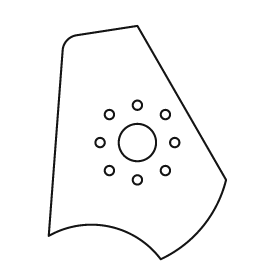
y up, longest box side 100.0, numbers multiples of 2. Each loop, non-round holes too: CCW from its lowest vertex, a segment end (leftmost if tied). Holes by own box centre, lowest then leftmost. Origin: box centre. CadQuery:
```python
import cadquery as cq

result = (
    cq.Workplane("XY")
    .moveTo(10.0, -50.0)
    .threePointArc((28.0, -36.0), (38.0, -16.0))
    .lineTo(0.0, 50.0)
    .lineTo(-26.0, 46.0)
    .threePointArc((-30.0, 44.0), (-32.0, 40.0))
    .lineTo(-38.0, -40.0)
    .threePointArc((-12.0, -36.0), (10.0, -50.0))
    .close()
    .moveTo(0.0, -16.0)
    .circle(2.0)
    .moveTo(-12.0, -12.0)
    .circle(2.0)
    .moveTo(12.0, -12.0)
    .circle(2.0)
    .moveTo(-16.0, 0.0)
    .circle(2.0)
    .moveTo(0.0, 0.0)
    .circle(8.0)
    .moveTo(16.0, 0.0)
    .circle(2.0)
    .moveTo(-12.0, 12.0)
    .circle(2.0)
    .moveTo(12.0, 12.0)
    .circle(2.0)
    .moveTo(0.0, 16.0)
    .circle(2.0)
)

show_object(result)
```